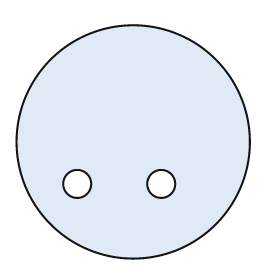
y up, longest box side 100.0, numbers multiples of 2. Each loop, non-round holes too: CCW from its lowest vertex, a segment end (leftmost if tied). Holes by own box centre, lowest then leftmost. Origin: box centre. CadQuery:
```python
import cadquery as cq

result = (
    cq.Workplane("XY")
    .moveTo(0.0, 0.0)
    .circle(50.0)
    .moveTo(-24.0, -18.0)
    .circle(6.0)
    .moveTo(12.0, -18.0)
    .circle(6.0)
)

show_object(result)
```